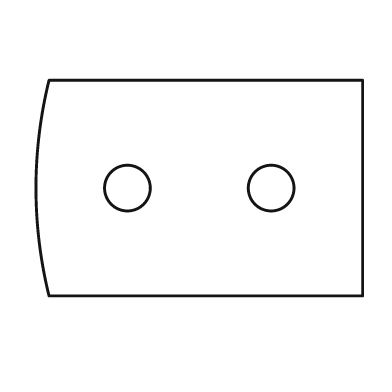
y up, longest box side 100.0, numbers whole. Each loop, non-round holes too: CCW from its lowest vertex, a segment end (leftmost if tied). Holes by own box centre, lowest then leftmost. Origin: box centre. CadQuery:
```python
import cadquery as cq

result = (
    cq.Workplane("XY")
    .moveTo(-46.0, -33.0)
    .lineTo(50.0, -33.0)
    .lineTo(50.0, 33.0)
    .lineTo(-46.0, 33.0)
    .threePointArc((-50.0, 0.0), (-46.0, -33.0))
    .close()
    .moveTo(-22.0, 0.0)
    .circle(7.0)
    .moveTo(22.0, 0.0)
    .circle(7.0)
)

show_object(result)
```